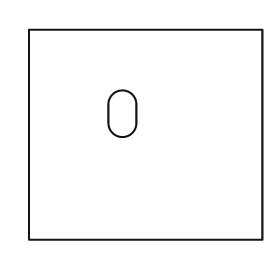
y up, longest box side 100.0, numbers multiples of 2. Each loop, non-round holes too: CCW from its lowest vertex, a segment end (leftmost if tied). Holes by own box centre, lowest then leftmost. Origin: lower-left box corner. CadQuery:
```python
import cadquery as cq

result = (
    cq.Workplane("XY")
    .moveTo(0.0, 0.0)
    .lineTo(100.0, 0.0)
    .lineTo(100.0, 90.0)
    .lineTo(0.0, 90.0)
    .close()
    .moveTo(34.0, 50.0)
    .threePointArc((40.0, 44.0), (46.0, 50.0))
    .lineTo(46.0, 58.0)
    .threePointArc((40.0, 64.0), (34.0, 58.0))
    .close()
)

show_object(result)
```